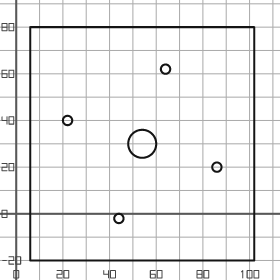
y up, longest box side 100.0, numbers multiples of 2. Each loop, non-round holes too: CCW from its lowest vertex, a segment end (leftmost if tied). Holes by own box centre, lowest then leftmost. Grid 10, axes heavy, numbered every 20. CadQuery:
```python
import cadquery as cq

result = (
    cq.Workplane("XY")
    .moveTo(6.0, -20.0)
    .lineTo(102.0, -20.0)
    .lineTo(102.0, 80.0)
    .lineTo(6.0, 80.0)
    .close()
    .moveTo(44.0, -2.0)
    .circle(2.0)
    .moveTo(86.0, 20.0)
    .circle(2.0)
    .moveTo(54.0, 30.0)
    .circle(6.0)
    .moveTo(22.0, 40.0)
    .circle(2.0)
    .moveTo(64.0, 62.0)
    .circle(2.0)
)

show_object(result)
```